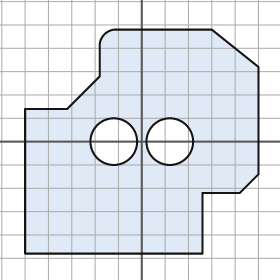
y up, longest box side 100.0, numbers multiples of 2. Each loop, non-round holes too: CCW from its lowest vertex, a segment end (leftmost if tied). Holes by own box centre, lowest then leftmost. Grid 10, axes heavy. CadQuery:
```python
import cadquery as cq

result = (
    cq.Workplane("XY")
    .moveTo(-50.0, -48.0)
    .lineTo(26.0, -48.0)
    .lineTo(26.0, -22.0)
    .lineTo(42.0, -22.0)
    .lineTo(50.0, -14.0)
    .lineTo(50.0, 32.0)
    .lineTo(30.0, 48.0)
    .lineTo(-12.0, 48.0)
    .threePointArc((-16.0, 46.0), (-18.0, 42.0))
    .lineTo(-18.0, 28.0)
    .lineTo(-32.0, 14.0)
    .lineTo(-50.0, 14.0)
    .close()
    .moveTo(-12.0, 0.0)
    .circle(10.0)
    .moveTo(12.0, 0.0)
    .circle(10.0)
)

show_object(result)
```